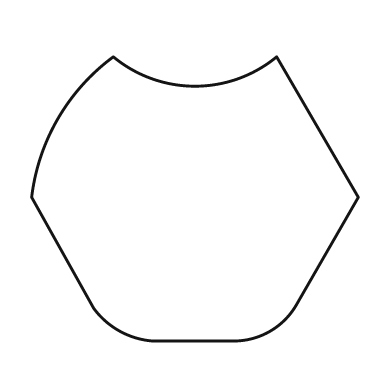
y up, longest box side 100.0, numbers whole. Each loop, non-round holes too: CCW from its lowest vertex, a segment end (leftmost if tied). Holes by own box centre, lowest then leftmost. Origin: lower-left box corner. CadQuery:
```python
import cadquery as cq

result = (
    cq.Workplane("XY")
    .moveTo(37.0, 0.0)
    .lineTo(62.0, 0.0)
    .threePointArc((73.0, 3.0), (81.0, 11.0))
    .lineTo(100.0, 44.0)
    .lineTo(75.0, 87.0)
    .threePointArc((50.0, 78.0), (25.0, 87.0))
    .threePointArc((8.0, 68.0), (0.0, 44.0))
    .lineTo(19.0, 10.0)
    .threePointArc((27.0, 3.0), (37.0, 0.0))
    .close()
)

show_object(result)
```